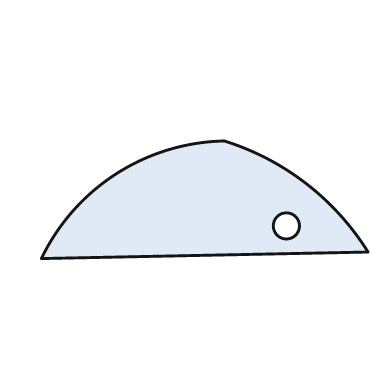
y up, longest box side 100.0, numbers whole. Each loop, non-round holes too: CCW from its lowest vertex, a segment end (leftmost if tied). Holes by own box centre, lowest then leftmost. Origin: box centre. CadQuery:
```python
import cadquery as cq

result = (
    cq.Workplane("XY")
    .moveTo(-50.0, -18.0)
    .lineTo(50.0, -16.0)
    .threePointArc((31.0, 5.0), (6.0, 18.0))
    .threePointArc((-27.0, 8.0), (-50.0, -18.0))
    .close()
    .moveTo(25.0, -8.0)
    .circle(4.0)
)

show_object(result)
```